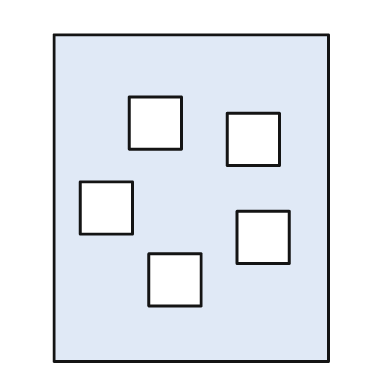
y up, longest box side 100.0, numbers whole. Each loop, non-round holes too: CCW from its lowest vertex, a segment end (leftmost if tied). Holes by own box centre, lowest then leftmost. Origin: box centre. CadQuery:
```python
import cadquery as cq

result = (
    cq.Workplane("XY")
    .moveTo(-42.0, -50.0)
    .lineTo(42.0, -50.0)
    .lineTo(42.0, 50.0)
    .lineTo(-42.0, 50.0)
    .close()
    .moveTo(-13.0, -33.0)
    .lineTo(3.0, -33.0)
    .lineTo(3.0, -17.0)
    .lineTo(-13.0, -17.0)
    .close()
    .moveTo(14.0, -20.0)
    .lineTo(30.0, -20.0)
    .lineTo(30.0, -4.0)
    .lineTo(14.0, -4.0)
    .close()
    .moveTo(-34.0, -11.0)
    .lineTo(-18.0, -11.0)
    .lineTo(-18.0, 5.0)
    .lineTo(-34.0, 5.0)
    .close()
    .moveTo(11.0, 10.0)
    .lineTo(27.0, 10.0)
    .lineTo(27.0, 26.0)
    .lineTo(11.0, 26.0)
    .close()
    .moveTo(-19.0, 15.0)
    .lineTo(-3.0, 15.0)
    .lineTo(-3.0, 31.0)
    .lineTo(-19.0, 31.0)
    .close()
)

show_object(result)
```